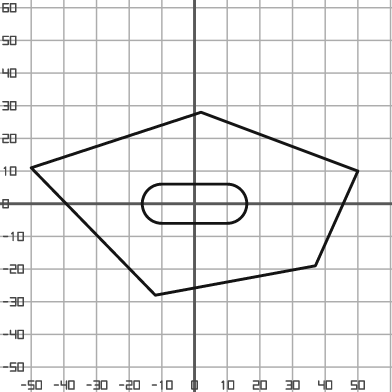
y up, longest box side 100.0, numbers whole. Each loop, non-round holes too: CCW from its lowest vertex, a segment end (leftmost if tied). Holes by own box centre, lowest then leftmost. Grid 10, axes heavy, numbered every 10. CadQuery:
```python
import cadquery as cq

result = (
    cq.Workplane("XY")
    .moveTo(-12.0, -28.0)
    .lineTo(37.0, -19.0)
    .lineTo(50.0, 10.0)
    .lineTo(2.0, 28.0)
    .lineTo(-50.0, 11.0)
    .close()
    .moveTo(-10.0, -6.0)
    .lineTo(10.0, -6.0)
    .threePointArc((16.0, 0.0), (10.0, 6.0))
    .lineTo(-10.0, 6.0)
    .threePointArc((-16.0, 0.0), (-10.0, -6.0))
    .close()
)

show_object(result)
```